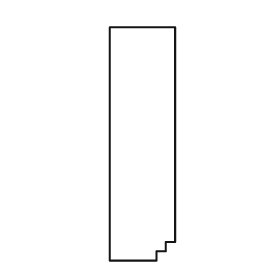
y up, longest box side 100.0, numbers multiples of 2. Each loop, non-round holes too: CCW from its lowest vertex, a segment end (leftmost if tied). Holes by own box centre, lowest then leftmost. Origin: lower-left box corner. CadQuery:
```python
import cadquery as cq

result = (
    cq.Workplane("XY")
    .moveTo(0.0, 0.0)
    .lineTo(20.0, 0.0)
    .lineTo(20.0, 4.0)
    .lineTo(24.0, 4.0)
    .lineTo(24.0, 8.0)
    .lineTo(28.0, 8.0)
    .lineTo(28.0, 100.0)
    .lineTo(0.0, 100.0)
    .close()
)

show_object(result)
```